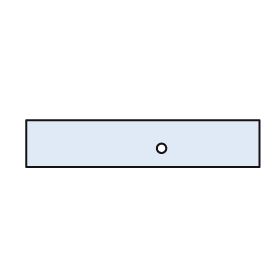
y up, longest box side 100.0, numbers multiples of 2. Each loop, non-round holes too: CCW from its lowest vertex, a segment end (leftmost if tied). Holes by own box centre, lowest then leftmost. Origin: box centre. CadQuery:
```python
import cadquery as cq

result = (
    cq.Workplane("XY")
    .moveTo(-50.0, -10.0)
    .lineTo(50.0, -10.0)
    .lineTo(50.0, 10.0)
    .lineTo(-50.0, 10.0)
    .close()
    .moveTo(8.0, -2.0)
    .circle(2.0)
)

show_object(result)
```